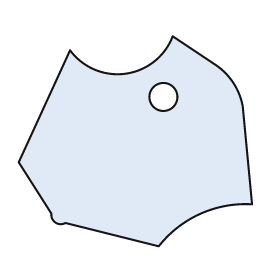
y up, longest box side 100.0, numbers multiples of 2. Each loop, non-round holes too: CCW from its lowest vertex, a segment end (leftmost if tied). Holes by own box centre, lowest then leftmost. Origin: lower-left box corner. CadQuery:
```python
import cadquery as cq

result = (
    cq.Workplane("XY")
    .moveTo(60.0, 0.0)
    .threePointArc((78.0, 14.0), (100.0, 18.0))
    .lineTo(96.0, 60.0)
    .threePointArc((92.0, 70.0), (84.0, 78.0))
    .lineTo(66.0, 90.0)
    .threePointArc((46.0, 74.0), (22.0, 84.0))
    .lineTo(0.0, 36.0)
    .lineTo(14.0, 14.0)
    .threePointArc((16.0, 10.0), (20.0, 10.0))
    .close()
    .moveTo(62.0, 64.0)
    .circle(6.0)
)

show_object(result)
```